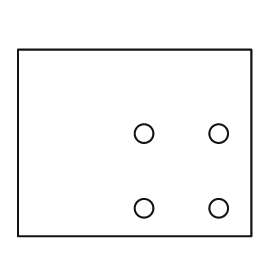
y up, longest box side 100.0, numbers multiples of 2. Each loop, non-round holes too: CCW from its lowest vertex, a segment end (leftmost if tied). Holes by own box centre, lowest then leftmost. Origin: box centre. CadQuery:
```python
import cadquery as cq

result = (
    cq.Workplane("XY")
    .moveTo(-50.0, -40.0)
    .lineTo(50.0, -40.0)
    .lineTo(50.0, 40.0)
    .lineTo(-50.0, 40.0)
    .close()
    .moveTo(4.0, -28.0)
    .circle(4.0)
    .moveTo(36.0, -28.0)
    .circle(4.0)
    .moveTo(4.0, 4.0)
    .circle(4.0)
    .moveTo(36.0, 4.0)
    .circle(4.0)
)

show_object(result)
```